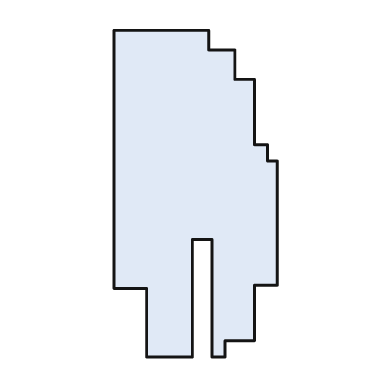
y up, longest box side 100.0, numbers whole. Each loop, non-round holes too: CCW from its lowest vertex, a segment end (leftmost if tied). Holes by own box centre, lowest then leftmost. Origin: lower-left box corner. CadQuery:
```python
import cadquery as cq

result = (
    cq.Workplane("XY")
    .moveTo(10.0, 0.0)
    .lineTo(24.0, 0.0)
    .lineTo(24.0, 36.0)
    .lineTo(30.0, 36.0)
    .lineTo(30.0, 0.0)
    .lineTo(34.0, 0.0)
    .lineTo(34.0, 5.0)
    .lineTo(43.0, 5.0)
    .lineTo(43.0, 22.0)
    .lineTo(50.0, 22.0)
    .lineTo(50.0, 60.0)
    .lineTo(47.0, 60.0)
    .lineTo(47.0, 65.0)
    .lineTo(43.0, 65.0)
    .lineTo(43.0, 85.0)
    .lineTo(37.0, 85.0)
    .lineTo(37.0, 94.0)
    .lineTo(29.0, 94.0)
    .lineTo(29.0, 100.0)
    .lineTo(0.0, 100.0)
    .lineTo(0.0, 21.0)
    .lineTo(10.0, 21.0)
    .close()
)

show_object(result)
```